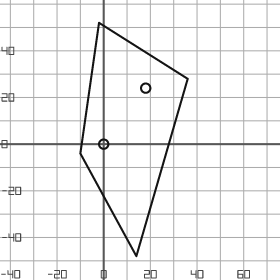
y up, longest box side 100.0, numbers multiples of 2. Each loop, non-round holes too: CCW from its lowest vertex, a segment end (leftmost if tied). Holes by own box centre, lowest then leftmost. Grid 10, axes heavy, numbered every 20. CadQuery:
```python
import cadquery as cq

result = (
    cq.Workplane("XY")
    .moveTo(14.0, -48.0)
    .lineTo(36.0, 28.0)
    .lineTo(-2.0, 52.0)
    .lineTo(-10.0, -4.0)
    .close()
    .moveTo(0.0, 0.0)
    .circle(2.0)
    .moveTo(18.0, 24.0)
    .circle(2.0)
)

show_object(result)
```